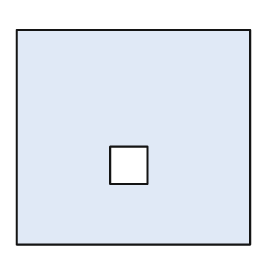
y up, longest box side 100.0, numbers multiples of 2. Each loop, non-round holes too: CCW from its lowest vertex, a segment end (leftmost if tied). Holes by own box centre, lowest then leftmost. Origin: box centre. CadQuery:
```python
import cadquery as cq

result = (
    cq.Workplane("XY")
    .moveTo(-50.0, -46.0)
    .lineTo(50.0, -46.0)
    .lineTo(50.0, 46.0)
    .lineTo(-50.0, 46.0)
    .close()
    .moveTo(-10.0, -20.0)
    .lineTo(6.0, -20.0)
    .lineTo(6.0, -4.0)
    .lineTo(-10.0, -4.0)
    .close()
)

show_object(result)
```